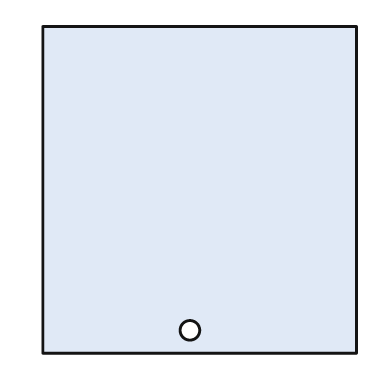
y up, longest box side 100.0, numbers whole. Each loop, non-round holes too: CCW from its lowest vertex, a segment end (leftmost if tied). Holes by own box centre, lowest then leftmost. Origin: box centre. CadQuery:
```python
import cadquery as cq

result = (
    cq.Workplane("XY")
    .moveTo(-48.0, -50.0)
    .lineTo(48.0, -50.0)
    .lineTo(48.0, 50.0)
    .lineTo(-48.0, 50.0)
    .close()
    .moveTo(-3.0, -43.0)
    .circle(3.0)
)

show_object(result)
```